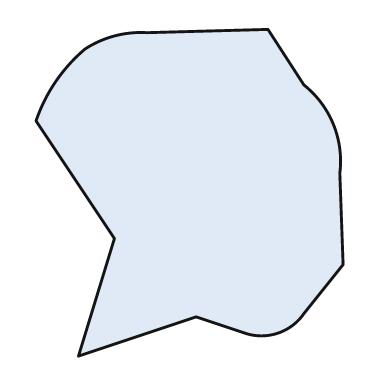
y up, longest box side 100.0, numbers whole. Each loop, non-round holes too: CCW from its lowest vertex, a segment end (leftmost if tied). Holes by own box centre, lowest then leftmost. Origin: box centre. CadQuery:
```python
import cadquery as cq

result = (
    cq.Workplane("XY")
    .moveTo(-34.0, -50.0)
    .lineTo(2.0, -38.0)
    .lineTo(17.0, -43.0)
    .threePointArc((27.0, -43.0), (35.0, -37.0))
    .lineTo(47.0, -22.0)
    .lineTo(46.0, 6.0)
    .threePointArc((44.0, 21.0), (35.0, 33.0))
    .lineTo(24.0, 50.0)
    .lineTo(-13.0, 49.0)
    .threePointArc((-23.0, 48.0), (-32.0, 44.0))
    .threePointArc((-41.0, 34.0), (-47.0, 22.0))
    .lineTo(-23.0, -14.0)
    .close()
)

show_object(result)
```